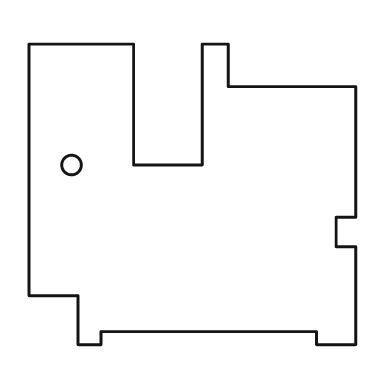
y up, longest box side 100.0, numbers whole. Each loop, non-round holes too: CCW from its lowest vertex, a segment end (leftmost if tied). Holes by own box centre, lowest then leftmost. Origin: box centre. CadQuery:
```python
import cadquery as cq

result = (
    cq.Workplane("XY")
    .moveTo(-35.0, -46.0)
    .lineTo(-28.0, -46.0)
    .lineTo(-28.0, -42.0)
    .lineTo(38.0, -42.0)
    .lineTo(38.0, -46.0)
    .lineTo(50.0, -46.0)
    .lineTo(50.0, -16.0)
    .lineTo(44.0, -16.0)
    .lineTo(44.0, -7.0)
    .lineTo(50.0, -7.0)
    .lineTo(50.0, 33.0)
    .lineTo(11.0, 33.0)
    .lineTo(11.0, 46.0)
    .lineTo(3.0, 46.0)
    .lineTo(3.0, 9.0)
    .lineTo(-18.0, 9.0)
    .lineTo(-18.0, 46.0)
    .lineTo(-50.0, 46.0)
    .lineTo(-50.0, -31.0)
    .lineTo(-35.0, -31.0)
    .close()
    .moveTo(-37.0, 9.0)
    .circle(3.0)
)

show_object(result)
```